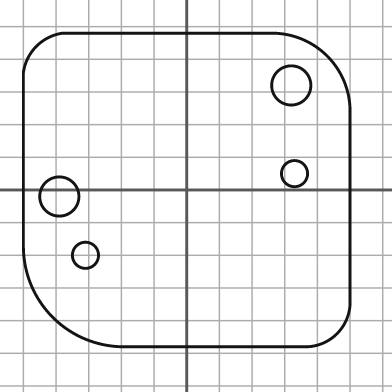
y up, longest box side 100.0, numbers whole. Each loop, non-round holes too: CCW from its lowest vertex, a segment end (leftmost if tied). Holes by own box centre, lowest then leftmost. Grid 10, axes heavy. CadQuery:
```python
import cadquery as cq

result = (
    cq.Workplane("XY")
    .moveTo(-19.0, -48.0)
    .lineTo(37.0, -48.0)
    .threePointArc((46.0, -44.0), (50.0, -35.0))
    .lineTo(50.0, 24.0)
    .threePointArc((43.0, 41.0), (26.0, 48.0))
    .lineTo(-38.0, 48.0)
    .threePointArc((-46.0, 44.0), (-50.0, 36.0))
    .lineTo(-50.0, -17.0)
    .threePointArc((-41.0, -39.0), (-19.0, -48.0))
    .close()
    .moveTo(-31.0, -20.0)
    .circle(4.0)
    .moveTo(-39.0, -2.0)
    .circle(6.0)
    .moveTo(33.0, 5.0)
    .circle(4.0)
    .moveTo(32.0, 32.0)
    .circle(6.0)
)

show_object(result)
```